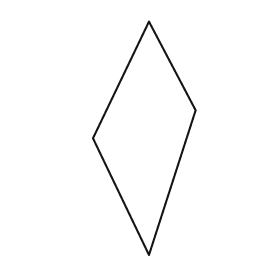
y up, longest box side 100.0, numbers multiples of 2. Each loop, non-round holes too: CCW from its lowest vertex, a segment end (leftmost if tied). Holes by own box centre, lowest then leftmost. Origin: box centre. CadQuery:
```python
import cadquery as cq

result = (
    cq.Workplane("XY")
    .moveTo(2.0, -50.0)
    .lineTo(22.0, 12.0)
    .lineTo(2.0, 50.0)
    .lineTo(-22.0, 0.0)
    .close()
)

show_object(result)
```